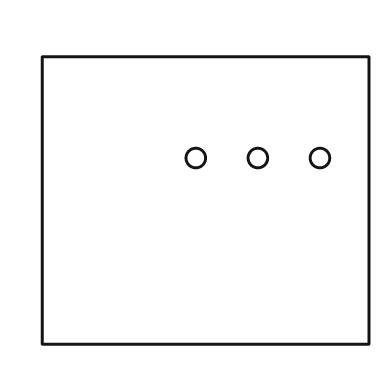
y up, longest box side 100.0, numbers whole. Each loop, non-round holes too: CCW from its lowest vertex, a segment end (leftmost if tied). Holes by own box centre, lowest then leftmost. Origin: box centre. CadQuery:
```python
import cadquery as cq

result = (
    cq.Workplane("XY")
    .moveTo(-50.0, -44.0)
    .lineTo(50.0, -44.0)
    .lineTo(50.0, 44.0)
    .lineTo(-50.0, 44.0)
    .close()
    .moveTo(-3.0, 13.0)
    .circle(3.0)
    .moveTo(16.0, 13.0)
    .circle(3.0)
    .moveTo(35.0, 13.0)
    .circle(3.0)
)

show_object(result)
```